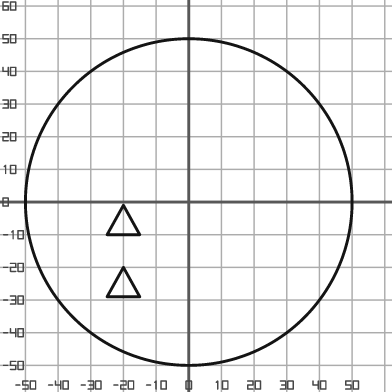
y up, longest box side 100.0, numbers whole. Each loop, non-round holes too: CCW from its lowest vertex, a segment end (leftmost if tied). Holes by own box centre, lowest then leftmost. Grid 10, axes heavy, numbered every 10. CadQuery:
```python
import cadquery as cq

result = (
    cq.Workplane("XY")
    .moveTo(0.0, 0.0)
    .circle(50.0)
    .moveTo(-25.0, -29.0)
    .lineTo(-15.0, -29.0)
    .lineTo(-20.0, -20.0)
    .close()
    .moveTo(-25.0, -10.0)
    .lineTo(-15.0, -10.0)
    .lineTo(-20.0, -1.0)
    .close()
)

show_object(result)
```